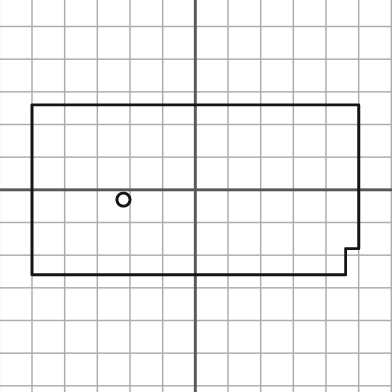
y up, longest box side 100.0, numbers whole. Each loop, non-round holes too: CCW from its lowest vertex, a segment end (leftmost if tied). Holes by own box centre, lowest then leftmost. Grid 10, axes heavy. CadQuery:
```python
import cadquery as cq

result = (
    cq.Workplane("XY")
    .moveTo(-50.0, -26.0)
    .lineTo(46.0, -26.0)
    .lineTo(46.0, -18.0)
    .lineTo(50.0, -18.0)
    .lineTo(50.0, 26.0)
    .lineTo(-50.0, 26.0)
    .close()
    .moveTo(-22.0, -3.0)
    .circle(2.0)
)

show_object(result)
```